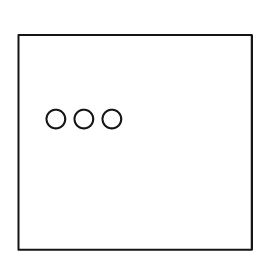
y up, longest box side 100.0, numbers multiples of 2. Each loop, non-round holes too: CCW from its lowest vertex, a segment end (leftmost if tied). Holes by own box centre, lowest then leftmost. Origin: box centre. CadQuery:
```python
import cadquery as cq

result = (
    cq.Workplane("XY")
    .moveTo(-50.0, -46.0)
    .lineTo(50.0, -46.0)
    .lineTo(50.0, 46.0)
    .lineTo(-50.0, 46.0)
    .close()
    .moveTo(-34.0, 10.0)
    .circle(4.0)
    .moveTo(-22.0, 10.0)
    .circle(4.0)
    .moveTo(-10.0, 10.0)
    .circle(4.0)
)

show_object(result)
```